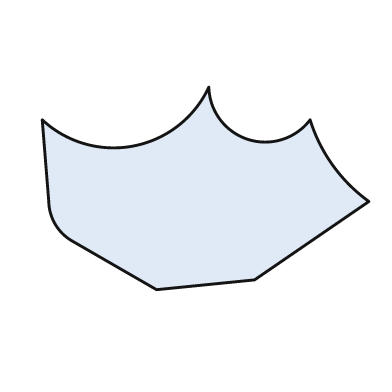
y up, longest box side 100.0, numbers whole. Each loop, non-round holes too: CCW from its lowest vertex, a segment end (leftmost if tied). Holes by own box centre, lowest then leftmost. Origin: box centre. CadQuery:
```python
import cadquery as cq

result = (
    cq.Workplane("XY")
    .moveTo(-15.0, -31.0)
    .lineTo(15.0, -28.0)
    .lineTo(50.0, -4.0)
    .threePointArc((39.0, 7.0), (32.0, 21.0))
    .threePointArc((13.0, 15.0), (1.0, 31.0))
    .threePointArc((-22.0, 13.0), (-50.0, 21.0))
    .lineTo(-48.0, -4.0)
    .threePointArc((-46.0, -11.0), (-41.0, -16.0))
    .close()
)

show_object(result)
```